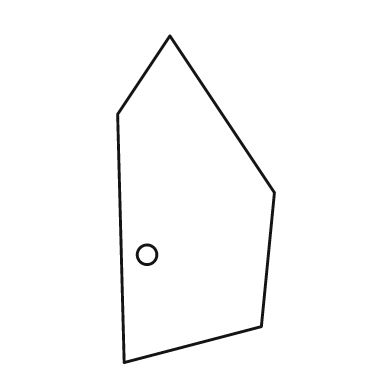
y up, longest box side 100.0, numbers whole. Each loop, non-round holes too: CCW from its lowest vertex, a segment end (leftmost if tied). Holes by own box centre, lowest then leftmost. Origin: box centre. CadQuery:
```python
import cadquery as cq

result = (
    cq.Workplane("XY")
    .moveTo(-22.0, -50.0)
    .lineTo(20.0, -39.0)
    .lineTo(24.0, 2.0)
    .lineTo(-8.0, 50.0)
    .lineTo(-24.0, 26.0)
    .close()
    .moveTo(-15.0, -17.0)
    .circle(3.0)
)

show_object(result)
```